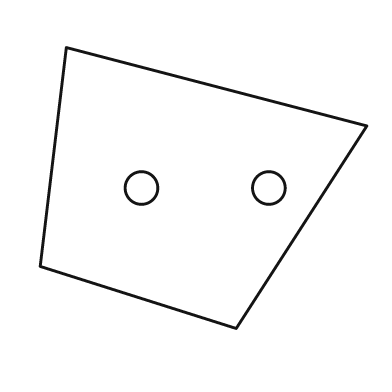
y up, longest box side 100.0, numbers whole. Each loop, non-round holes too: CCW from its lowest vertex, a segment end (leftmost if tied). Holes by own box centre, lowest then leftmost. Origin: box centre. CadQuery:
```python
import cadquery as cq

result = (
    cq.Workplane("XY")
    .moveTo(10.0, -43.0)
    .lineTo(50.0, 19.0)
    .lineTo(-42.0, 43.0)
    .lineTo(-50.0, -24.0)
    .close()
    .moveTo(-19.0, 0.0)
    .circle(5.0)
    .moveTo(20.0, 0.0)
    .circle(5.0)
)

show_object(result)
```